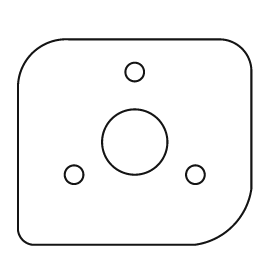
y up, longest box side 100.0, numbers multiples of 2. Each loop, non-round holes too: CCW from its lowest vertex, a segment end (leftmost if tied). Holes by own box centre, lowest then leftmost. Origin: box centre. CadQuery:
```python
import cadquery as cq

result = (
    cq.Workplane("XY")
    .moveTo(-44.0, -44.0)
    .lineTo(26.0, -44.0)
    .threePointArc((42.0, -36.0), (50.0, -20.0))
    .lineTo(50.0, 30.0)
    .threePointArc((46.0, 40.0), (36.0, 44.0))
    .lineTo(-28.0, 44.0)
    .threePointArc((-44.0, 38.0), (-50.0, 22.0))
    .lineTo(-50.0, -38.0)
    .threePointArc((-48.0, -42.0), (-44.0, -44.0))
    .close()
    .moveTo(-26.0, -14.0)
    .circle(4.0)
    .moveTo(26.0, -14.0)
    .circle(4.0)
    .moveTo(0.0, 0.0)
    .circle(14.0)
    .moveTo(0.0, 30.0)
    .circle(4.0)
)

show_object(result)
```